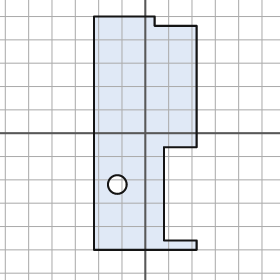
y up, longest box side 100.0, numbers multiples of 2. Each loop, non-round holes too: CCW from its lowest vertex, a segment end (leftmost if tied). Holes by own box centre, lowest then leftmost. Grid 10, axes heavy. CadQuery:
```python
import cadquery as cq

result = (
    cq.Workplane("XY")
    .moveTo(-22.0, -50.0)
    .lineTo(22.0, -50.0)
    .lineTo(22.0, -46.0)
    .lineTo(8.0, -46.0)
    .lineTo(8.0, -6.0)
    .lineTo(22.0, -6.0)
    .lineTo(22.0, 46.0)
    .lineTo(4.0, 46.0)
    .lineTo(4.0, 50.0)
    .lineTo(-22.0, 50.0)
    .close()
    .moveTo(-12.0, -22.0)
    .circle(4.0)
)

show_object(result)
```